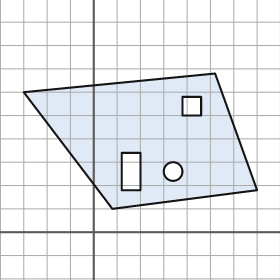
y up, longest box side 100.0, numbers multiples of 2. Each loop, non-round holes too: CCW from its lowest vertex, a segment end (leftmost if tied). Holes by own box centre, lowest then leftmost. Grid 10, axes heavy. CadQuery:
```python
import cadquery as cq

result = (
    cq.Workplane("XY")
    .moveTo(8.0, 10.0)
    .lineTo(70.0, 18.0)
    .lineTo(52.0, 68.0)
    .lineTo(-30.0, 60.0)
    .close()
    .moveTo(12.0, 18.0)
    .lineTo(20.0, 18.0)
    .lineTo(20.0, 34.0)
    .lineTo(12.0, 34.0)
    .close()
    .moveTo(34.0, 26.0)
    .circle(4.0)
    .moveTo(38.0, 50.0)
    .lineTo(46.0, 50.0)
    .lineTo(46.0, 58.0)
    .lineTo(38.0, 58.0)
    .close()
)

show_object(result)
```